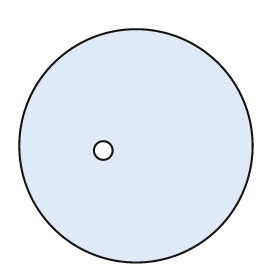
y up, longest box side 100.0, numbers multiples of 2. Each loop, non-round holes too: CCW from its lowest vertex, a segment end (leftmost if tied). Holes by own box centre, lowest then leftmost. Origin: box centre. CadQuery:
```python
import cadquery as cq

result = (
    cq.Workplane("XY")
    .moveTo(0.0, 0.0)
    .circle(50.0)
    .moveTo(-14.0, -2.0)
    .circle(4.0)
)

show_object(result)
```